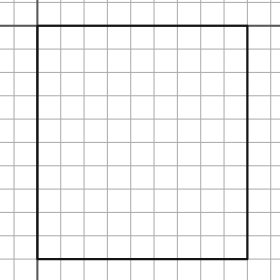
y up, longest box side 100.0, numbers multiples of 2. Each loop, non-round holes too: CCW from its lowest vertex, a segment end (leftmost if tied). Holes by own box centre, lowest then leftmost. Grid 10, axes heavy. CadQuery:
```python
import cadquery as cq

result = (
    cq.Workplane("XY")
    .moveTo(0.0, -100.0)
    .lineTo(90.0, -100.0)
    .lineTo(90.0, 0.0)
    .lineTo(0.0, 0.0)
    .close()
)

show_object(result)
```